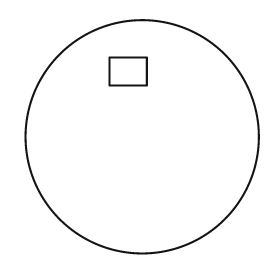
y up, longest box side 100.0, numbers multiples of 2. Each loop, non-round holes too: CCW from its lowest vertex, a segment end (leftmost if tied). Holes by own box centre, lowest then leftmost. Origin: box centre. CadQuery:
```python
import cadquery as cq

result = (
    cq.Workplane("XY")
    .moveTo(0.0, 0.0)
    .circle(50.0)
    .moveTo(-14.0, 22.0)
    .lineTo(2.0, 22.0)
    .lineTo(2.0, 34.0)
    .lineTo(-14.0, 34.0)
    .close()
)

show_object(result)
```